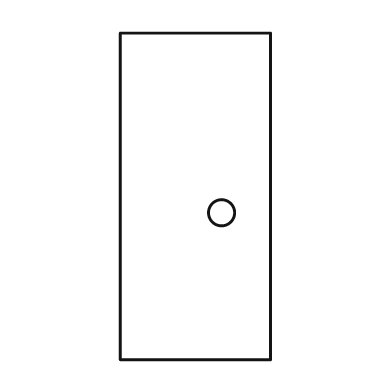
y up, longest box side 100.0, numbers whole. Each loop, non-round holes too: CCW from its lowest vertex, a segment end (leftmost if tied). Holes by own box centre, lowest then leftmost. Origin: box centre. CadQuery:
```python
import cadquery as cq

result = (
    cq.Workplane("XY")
    .moveTo(-23.0, -50.0)
    .lineTo(23.0, -50.0)
    .lineTo(23.0, 50.0)
    .lineTo(-23.0, 50.0)
    .close()
    .moveTo(8.0, -5.0)
    .circle(4.0)
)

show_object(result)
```